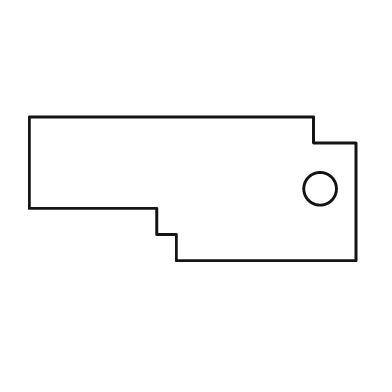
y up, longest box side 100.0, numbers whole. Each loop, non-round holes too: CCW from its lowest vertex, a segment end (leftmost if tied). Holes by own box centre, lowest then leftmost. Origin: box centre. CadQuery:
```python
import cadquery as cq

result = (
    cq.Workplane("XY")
    .moveTo(-5.0, -22.0)
    .lineTo(50.0, -22.0)
    .lineTo(50.0, 14.0)
    .lineTo(37.0, 14.0)
    .lineTo(37.0, 22.0)
    .lineTo(-50.0, 22.0)
    .lineTo(-50.0, -6.0)
    .lineTo(-11.0, -6.0)
    .lineTo(-11.0, -14.0)
    .lineTo(-5.0, -14.0)
    .close()
    .moveTo(39.0, 0.0)
    .circle(5.0)
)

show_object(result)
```